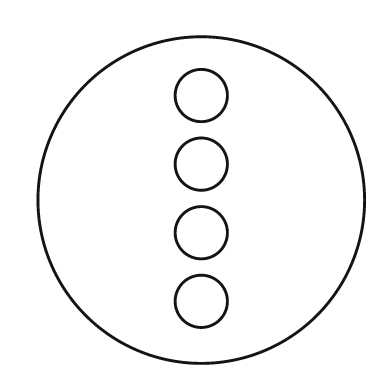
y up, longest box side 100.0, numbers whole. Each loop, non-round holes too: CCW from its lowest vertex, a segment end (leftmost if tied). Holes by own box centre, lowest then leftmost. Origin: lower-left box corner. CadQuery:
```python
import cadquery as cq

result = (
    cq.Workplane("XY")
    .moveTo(50.0, 50.0)
    .circle(50.0)
    .moveTo(50.0, 19.0)
    .circle(8.0)
    .moveTo(50.0, 40.0)
    .circle(8.0)
    .moveTo(50.0, 61.0)
    .circle(8.0)
    .moveTo(50.0, 82.0)
    .circle(8.0)
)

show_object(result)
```